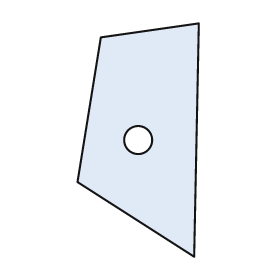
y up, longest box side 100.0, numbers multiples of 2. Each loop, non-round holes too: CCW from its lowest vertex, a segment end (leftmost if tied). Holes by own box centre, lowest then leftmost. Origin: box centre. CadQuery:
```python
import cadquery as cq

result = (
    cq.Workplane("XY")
    .moveTo(24.0, -50.0)
    .lineTo(26.0, 50.0)
    .lineTo(-16.0, 44.0)
    .lineTo(-26.0, -18.0)
    .close()
    .moveTo(0.0, 0.0)
    .circle(6.0)
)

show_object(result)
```